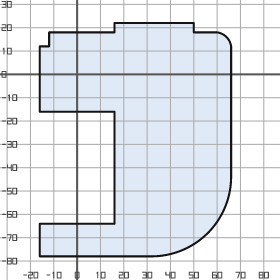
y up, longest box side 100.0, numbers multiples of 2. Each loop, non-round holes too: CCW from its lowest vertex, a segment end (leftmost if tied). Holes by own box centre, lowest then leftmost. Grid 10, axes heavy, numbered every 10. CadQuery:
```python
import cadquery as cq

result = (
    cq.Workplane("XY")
    .moveTo(-16.0, -78.0)
    .lineTo(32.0, -78.0)
    .threePointArc((56.0, -68.0), (66.0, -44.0))
    .lineTo(66.0, 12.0)
    .threePointArc((64.0, 16.0), (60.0, 18.0))
    .lineTo(50.0, 18.0)
    .lineTo(50.0, 22.0)
    .lineTo(16.0, 22.0)
    .lineTo(16.0, 18.0)
    .lineTo(-12.0, 18.0)
    .lineTo(-12.0, 12.0)
    .lineTo(-16.0, 12.0)
    .lineTo(-16.0, -16.0)
    .lineTo(16.0, -16.0)
    .lineTo(16.0, -64.0)
    .lineTo(-16.0, -64.0)
    .close()
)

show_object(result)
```